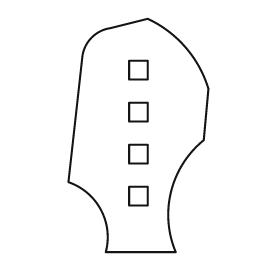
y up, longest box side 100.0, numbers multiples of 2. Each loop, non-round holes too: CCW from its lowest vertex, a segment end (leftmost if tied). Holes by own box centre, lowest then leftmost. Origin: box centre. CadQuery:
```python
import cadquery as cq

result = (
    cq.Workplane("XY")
    .moveTo(-14.0, -50.0)
    .lineTo(16.0, -50.0)
    .threePointArc((14.0, -24.0), (28.0, -2.0))
    .lineTo(30.0, 20.0)
    .threePointArc((20.0, 38.0), (4.0, 50.0))
    .lineTo(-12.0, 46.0)
    .threePointArc((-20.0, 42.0), (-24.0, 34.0))
    .lineTo(-30.0, -20.0)
    .threePointArc((-16.0, -32.0), (-14.0, -50.0))
    .close()
    .moveTo(-4.0, -30.0)
    .lineTo(4.0, -30.0)
    .lineTo(4.0, -22.0)
    .lineTo(-4.0, -22.0)
    .close()
    .moveTo(-4.0, -12.0)
    .lineTo(4.0, -12.0)
    .lineTo(4.0, -4.0)
    .lineTo(-4.0, -4.0)
    .close()
    .moveTo(-4.0, 6.0)
    .lineTo(4.0, 6.0)
    .lineTo(4.0, 14.0)
    .lineTo(-4.0, 14.0)
    .close()
    .moveTo(-4.0, 24.0)
    .lineTo(4.0, 24.0)
    .lineTo(4.0, 32.0)
    .lineTo(-4.0, 32.0)
    .close()
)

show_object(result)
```